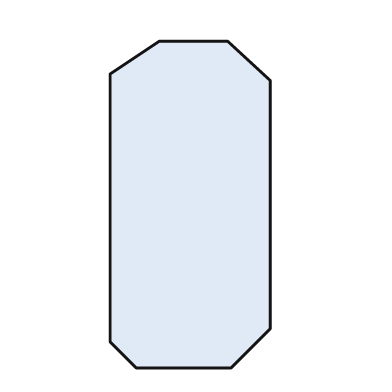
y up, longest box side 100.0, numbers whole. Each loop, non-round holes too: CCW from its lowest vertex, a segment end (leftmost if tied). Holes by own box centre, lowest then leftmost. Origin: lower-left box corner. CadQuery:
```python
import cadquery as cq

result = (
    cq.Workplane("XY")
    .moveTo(8.0, 0.0)
    .lineTo(37.0, 0.0)
    .lineTo(49.0, 12.0)
    .lineTo(49.0, 88.0)
    .lineTo(36.0, 100.0)
    .lineTo(15.0, 100.0)
    .lineTo(0.0, 90.0)
    .lineTo(0.0, 8.0)
    .close()
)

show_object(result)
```